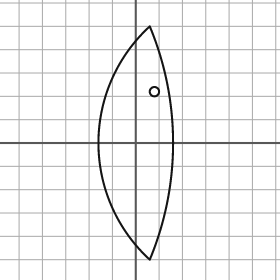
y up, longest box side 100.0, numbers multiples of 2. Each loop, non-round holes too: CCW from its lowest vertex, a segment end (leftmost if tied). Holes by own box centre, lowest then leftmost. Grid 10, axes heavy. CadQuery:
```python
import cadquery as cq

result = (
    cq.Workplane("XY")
    .moveTo(6.0, -50.0)
    .threePointArc((16.0, 0.0), (6.0, 50.0))
    .threePointArc((-16.0, 0.0), (6.0, -50.0))
    .close()
    .moveTo(8.0, 22.0)
    .circle(2.0)
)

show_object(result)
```